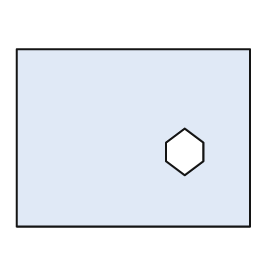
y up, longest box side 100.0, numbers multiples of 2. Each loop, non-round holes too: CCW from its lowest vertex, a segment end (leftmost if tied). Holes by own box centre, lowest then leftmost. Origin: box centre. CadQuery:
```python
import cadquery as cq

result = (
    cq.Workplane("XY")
    .moveTo(-50.0, -38.0)
    .lineTo(50.0, -38.0)
    .lineTo(50.0, 38.0)
    .lineTo(-50.0, 38.0)
    .close()
    .moveTo(22.0, -16.0)
    .lineTo(30.0, -10.0)
    .lineTo(30.0, -2.0)
    .lineTo(22.0, 4.0)
    .lineTo(14.0, -2.0)
    .lineTo(14.0, -10.0)
    .close()
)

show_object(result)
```